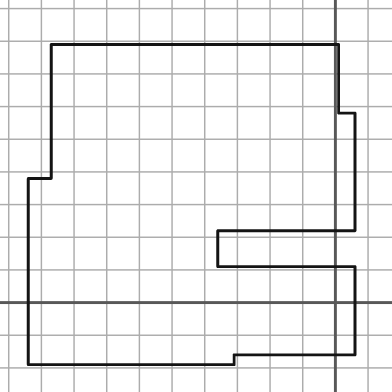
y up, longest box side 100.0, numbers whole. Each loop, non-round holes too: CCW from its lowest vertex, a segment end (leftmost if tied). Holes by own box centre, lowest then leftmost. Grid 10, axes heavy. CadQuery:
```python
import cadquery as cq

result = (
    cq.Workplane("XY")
    .moveTo(-94.0, -19.0)
    .lineTo(-31.0, -19.0)
    .lineTo(-31.0, -16.0)
    .lineTo(6.0, -16.0)
    .lineTo(6.0, 11.0)
    .lineTo(-36.0, 11.0)
    .lineTo(-36.0, 22.0)
    .lineTo(6.0, 22.0)
    .lineTo(6.0, 58.0)
    .lineTo(1.0, 58.0)
    .lineTo(1.0, 79.0)
    .lineTo(-87.0, 79.0)
    .lineTo(-87.0, 38.0)
    .lineTo(-94.0, 38.0)
    .close()
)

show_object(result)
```